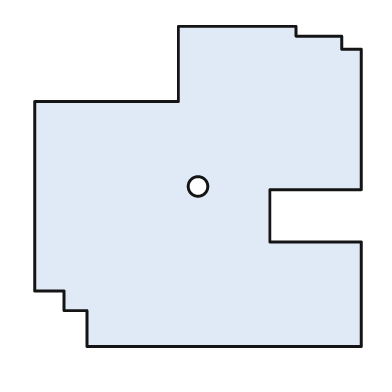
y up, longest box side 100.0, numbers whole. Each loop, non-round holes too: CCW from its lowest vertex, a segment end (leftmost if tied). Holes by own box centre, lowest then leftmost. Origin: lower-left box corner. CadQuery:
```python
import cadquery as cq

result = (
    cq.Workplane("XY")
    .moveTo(16.0, 0.0)
    .lineTo(100.0, 0.0)
    .lineTo(100.0, 32.0)
    .lineTo(72.0, 32.0)
    .lineTo(72.0, 48.0)
    .lineTo(100.0, 48.0)
    .lineTo(100.0, 91.0)
    .lineTo(94.0, 91.0)
    .lineTo(94.0, 95.0)
    .lineTo(80.0, 95.0)
    .lineTo(80.0, 98.0)
    .lineTo(44.0, 98.0)
    .lineTo(44.0, 75.0)
    .lineTo(0.0, 75.0)
    .lineTo(0.0, 17.0)
    .lineTo(9.0, 17.0)
    .lineTo(9.0, 11.0)
    .lineTo(16.0, 11.0)
    .close()
    .moveTo(50.0, 49.0)
    .circle(3.0)
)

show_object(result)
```